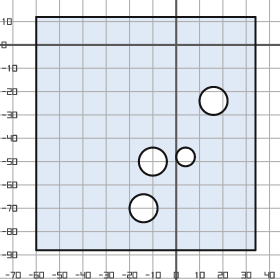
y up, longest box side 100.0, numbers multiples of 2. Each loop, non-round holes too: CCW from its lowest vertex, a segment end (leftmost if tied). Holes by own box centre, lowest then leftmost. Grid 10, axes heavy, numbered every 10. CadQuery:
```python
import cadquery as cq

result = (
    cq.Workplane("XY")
    .moveTo(-60.0, -88.0)
    .lineTo(34.0, -88.0)
    .lineTo(34.0, 12.0)
    .lineTo(-60.0, 12.0)
    .close()
    .moveTo(-14.0, -70.0)
    .circle(6.0)
    .moveTo(-10.0, -50.0)
    .circle(6.0)
    .moveTo(4.0, -48.0)
    .circle(4.0)
    .moveTo(16.0, -24.0)
    .circle(6.0)
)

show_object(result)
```